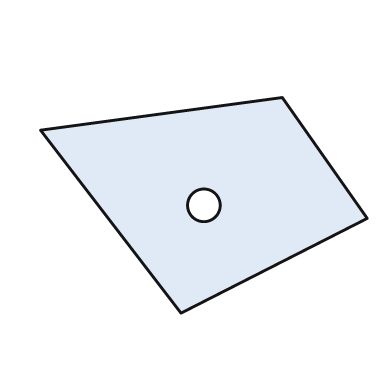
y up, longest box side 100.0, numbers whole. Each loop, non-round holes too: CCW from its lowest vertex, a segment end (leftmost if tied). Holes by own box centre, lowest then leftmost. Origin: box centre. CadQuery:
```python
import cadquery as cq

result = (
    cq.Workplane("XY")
    .moveTo(-7.0, -33.0)
    .lineTo(50.0, -4.0)
    .lineTo(24.0, 33.0)
    .lineTo(-50.0, 23.0)
    .close()
    .moveTo(0.0, 0.0)
    .circle(5.0)
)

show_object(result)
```